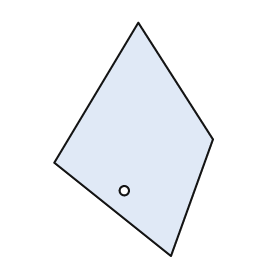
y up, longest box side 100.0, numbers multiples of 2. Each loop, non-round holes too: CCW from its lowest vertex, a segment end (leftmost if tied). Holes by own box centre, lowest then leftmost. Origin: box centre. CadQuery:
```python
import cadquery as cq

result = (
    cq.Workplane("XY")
    .moveTo(16.0, -50.0)
    .lineTo(34.0, 0.0)
    .lineTo(2.0, 50.0)
    .lineTo(-34.0, -10.0)
    .close()
    .moveTo(-4.0, -22.0)
    .circle(2.0)
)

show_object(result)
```